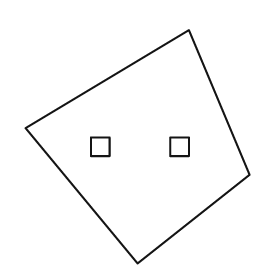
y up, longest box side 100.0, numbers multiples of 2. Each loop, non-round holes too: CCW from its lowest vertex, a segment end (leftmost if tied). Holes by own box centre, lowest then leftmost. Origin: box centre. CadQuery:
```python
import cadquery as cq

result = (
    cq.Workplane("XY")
    .moveTo(0.0, -50.0)
    .lineTo(48.0, -12.0)
    .lineTo(22.0, 50.0)
    .lineTo(-48.0, 8.0)
    .close()
    .moveTo(-20.0, -4.0)
    .lineTo(-12.0, -4.0)
    .lineTo(-12.0, 4.0)
    .lineTo(-20.0, 4.0)
    .close()
    .moveTo(14.0, -4.0)
    .lineTo(22.0, -4.0)
    .lineTo(22.0, 4.0)
    .lineTo(14.0, 4.0)
    .close()
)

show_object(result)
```